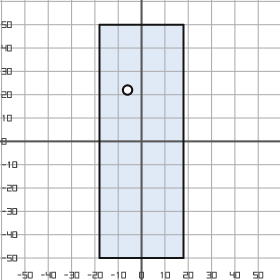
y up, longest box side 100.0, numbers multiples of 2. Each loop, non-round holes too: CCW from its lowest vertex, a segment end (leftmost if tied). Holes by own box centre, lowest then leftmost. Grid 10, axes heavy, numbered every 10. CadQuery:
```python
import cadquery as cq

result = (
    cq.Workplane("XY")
    .moveTo(-18.0, -50.0)
    .lineTo(18.0, -50.0)
    .lineTo(18.0, 50.0)
    .lineTo(-18.0, 50.0)
    .close()
    .moveTo(-6.0, 22.0)
    .circle(2.0)
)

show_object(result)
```